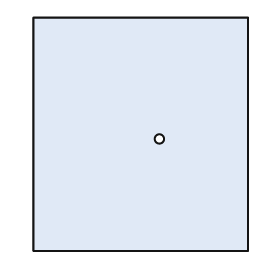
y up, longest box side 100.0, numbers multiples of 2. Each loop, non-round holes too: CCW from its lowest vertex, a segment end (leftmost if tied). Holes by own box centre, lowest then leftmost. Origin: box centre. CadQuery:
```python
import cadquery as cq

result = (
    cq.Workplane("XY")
    .moveTo(-46.0, -50.0)
    .lineTo(46.0, -50.0)
    .lineTo(46.0, 50.0)
    .lineTo(-46.0, 50.0)
    .close()
    .moveTo(8.0, -2.0)
    .circle(2.0)
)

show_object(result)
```